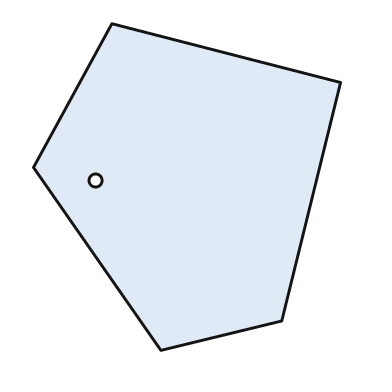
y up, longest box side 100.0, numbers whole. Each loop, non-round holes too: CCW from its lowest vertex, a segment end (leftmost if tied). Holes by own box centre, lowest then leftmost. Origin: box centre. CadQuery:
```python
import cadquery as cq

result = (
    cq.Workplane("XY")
    .moveTo(-8.0, -50.0)
    .lineTo(29.0, -41.0)
    .lineTo(47.0, 32.0)
    .lineTo(-23.0, 50.0)
    .lineTo(-47.0, 6.0)
    .close()
    .moveTo(-28.0, 2.0)
    .circle(2.0)
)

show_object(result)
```